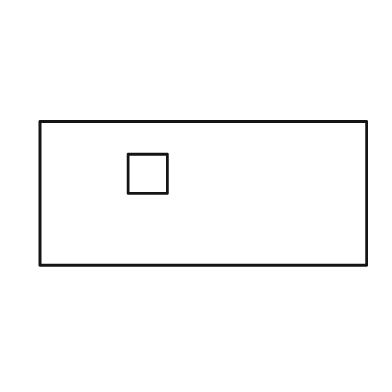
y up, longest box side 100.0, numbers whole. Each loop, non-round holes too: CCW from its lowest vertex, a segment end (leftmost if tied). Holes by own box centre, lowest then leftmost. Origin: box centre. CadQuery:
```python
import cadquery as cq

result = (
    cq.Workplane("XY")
    .moveTo(-50.0, -22.0)
    .lineTo(50.0, -22.0)
    .lineTo(50.0, 22.0)
    .lineTo(-50.0, 22.0)
    .close()
    .moveTo(-23.0, 0.0)
    .lineTo(-11.0, 0.0)
    .lineTo(-11.0, 12.0)
    .lineTo(-23.0, 12.0)
    .close()
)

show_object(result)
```